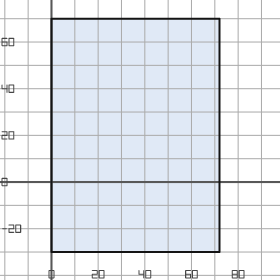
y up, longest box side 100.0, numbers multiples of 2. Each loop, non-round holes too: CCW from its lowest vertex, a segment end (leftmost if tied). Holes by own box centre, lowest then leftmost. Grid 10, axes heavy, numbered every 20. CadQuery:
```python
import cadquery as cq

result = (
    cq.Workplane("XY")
    .moveTo(0.0, -30.0)
    .lineTo(72.0, -30.0)
    .lineTo(72.0, 70.0)
    .lineTo(0.0, 70.0)
    .close()
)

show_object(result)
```